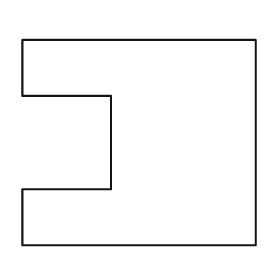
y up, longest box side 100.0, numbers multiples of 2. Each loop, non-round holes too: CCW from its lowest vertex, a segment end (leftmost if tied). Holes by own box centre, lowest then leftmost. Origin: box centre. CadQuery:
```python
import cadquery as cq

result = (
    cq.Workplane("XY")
    .moveTo(-50.0, -44.0)
    .lineTo(50.0, -44.0)
    .lineTo(50.0, 44.0)
    .lineTo(-50.0, 44.0)
    .lineTo(-50.0, 20.0)
    .lineTo(-12.0, 20.0)
    .lineTo(-12.0, -20.0)
    .lineTo(-50.0, -20.0)
    .close()
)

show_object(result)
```